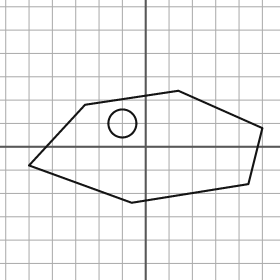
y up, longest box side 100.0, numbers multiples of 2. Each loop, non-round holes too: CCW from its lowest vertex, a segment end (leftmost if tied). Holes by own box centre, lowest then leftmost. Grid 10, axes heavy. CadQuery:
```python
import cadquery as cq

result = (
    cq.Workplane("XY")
    .moveTo(-6.0, -24.0)
    .lineTo(44.0, -16.0)
    .lineTo(50.0, 8.0)
    .lineTo(14.0, 24.0)
    .lineTo(-26.0, 18.0)
    .lineTo(-50.0, -8.0)
    .close()
    .moveTo(-10.0, 10.0)
    .circle(6.0)
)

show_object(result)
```